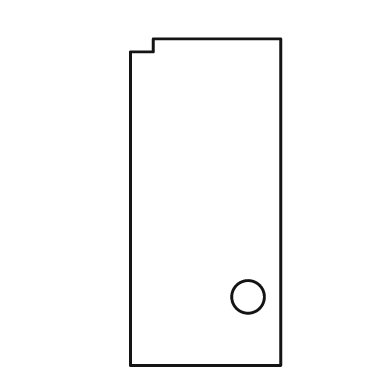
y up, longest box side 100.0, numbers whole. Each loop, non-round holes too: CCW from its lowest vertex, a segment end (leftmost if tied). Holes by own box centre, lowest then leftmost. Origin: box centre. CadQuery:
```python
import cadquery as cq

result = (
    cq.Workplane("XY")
    .moveTo(-23.0, -50.0)
    .lineTo(23.0, -50.0)
    .lineTo(23.0, 50.0)
    .lineTo(-16.0, 50.0)
    .lineTo(-16.0, 46.0)
    .lineTo(-23.0, 46.0)
    .close()
    .moveTo(13.0, -29.0)
    .circle(5.0)
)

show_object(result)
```